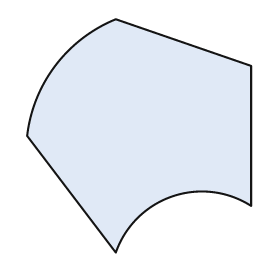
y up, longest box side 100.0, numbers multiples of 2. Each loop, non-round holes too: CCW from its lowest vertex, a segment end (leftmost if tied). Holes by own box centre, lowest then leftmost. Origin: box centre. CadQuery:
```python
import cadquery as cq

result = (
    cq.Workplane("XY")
    .moveTo(-10.0, -50.0)
    .threePointArc((14.0, -26.0), (48.0, -30.0))
    .lineTo(48.0, 30.0)
    .lineTo(-10.0, 50.0)
    .threePointArc((-36.0, 30.0), (-48.0, 0.0))
    .close()
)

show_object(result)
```